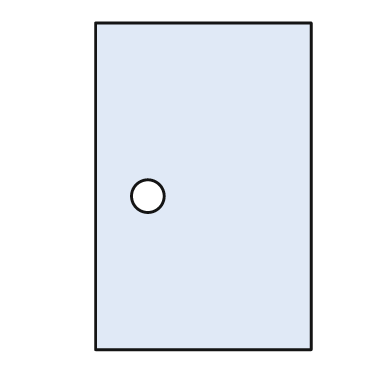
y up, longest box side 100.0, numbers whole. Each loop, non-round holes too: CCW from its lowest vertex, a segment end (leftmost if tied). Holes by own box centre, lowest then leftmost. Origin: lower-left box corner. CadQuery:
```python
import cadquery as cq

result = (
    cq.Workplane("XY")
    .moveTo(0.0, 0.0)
    .lineTo(66.0, 0.0)
    .lineTo(66.0, 100.0)
    .lineTo(0.0, 100.0)
    .close()
    .moveTo(16.0, 47.0)
    .circle(5.0)
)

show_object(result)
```